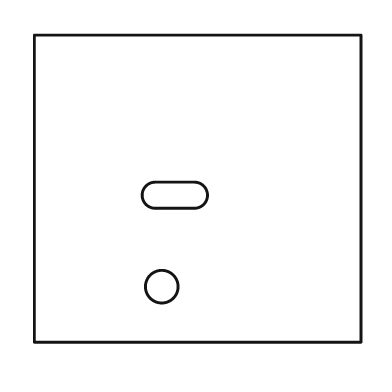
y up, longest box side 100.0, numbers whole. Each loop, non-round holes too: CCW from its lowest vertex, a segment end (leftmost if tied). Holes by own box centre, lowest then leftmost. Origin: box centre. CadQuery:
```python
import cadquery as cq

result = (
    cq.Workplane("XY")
    .moveTo(-50.0, -47.0)
    .lineTo(50.0, -47.0)
    .lineTo(50.0, 47.0)
    .lineTo(-50.0, 47.0)
    .close()
    .moveTo(-11.0, -30.0)
    .circle(5.0)
    .moveTo(-13.0, -6.0)
    .lineTo(-1.0, -6.0)
    .threePointArc((3.0, -2.0), (-1.0, 2.0))
    .lineTo(-13.0, 2.0)
    .threePointArc((-17.0, -2.0), (-13.0, -6.0))
    .close()
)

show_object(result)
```